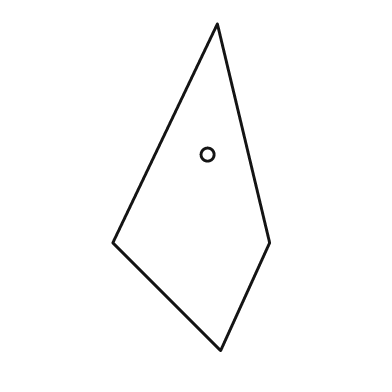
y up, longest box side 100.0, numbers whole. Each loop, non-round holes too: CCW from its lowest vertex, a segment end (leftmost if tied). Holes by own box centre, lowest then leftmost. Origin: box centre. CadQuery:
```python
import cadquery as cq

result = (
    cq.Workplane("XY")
    .moveTo(9.0, -50.0)
    .lineTo(24.0, -17.0)
    .lineTo(8.0, 50.0)
    .lineTo(-24.0, -17.0)
    .close()
    .moveTo(5.0, 10.0)
    .circle(2.0)
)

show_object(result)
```